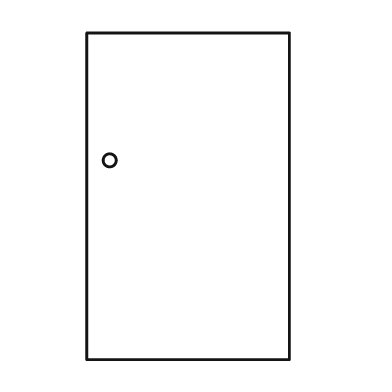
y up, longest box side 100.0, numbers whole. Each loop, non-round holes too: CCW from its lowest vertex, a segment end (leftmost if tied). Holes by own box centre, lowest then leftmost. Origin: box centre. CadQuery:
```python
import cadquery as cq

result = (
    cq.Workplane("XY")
    .moveTo(-31.0, -50.0)
    .lineTo(31.0, -50.0)
    .lineTo(31.0, 50.0)
    .lineTo(-31.0, 50.0)
    .close()
    .moveTo(-24.0, 11.0)
    .circle(2.0)
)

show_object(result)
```